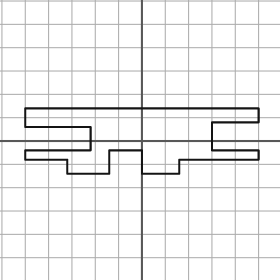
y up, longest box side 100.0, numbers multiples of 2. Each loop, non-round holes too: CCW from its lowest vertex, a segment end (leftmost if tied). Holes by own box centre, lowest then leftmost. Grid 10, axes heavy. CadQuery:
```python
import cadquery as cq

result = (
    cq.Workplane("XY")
    .moveTo(-32.0, -14.0)
    .lineTo(-14.0, -14.0)
    .lineTo(-14.0, -4.0)
    .lineTo(0.0, -4.0)
    .lineTo(0.0, -14.0)
    .lineTo(16.0, -14.0)
    .lineTo(16.0, -8.0)
    .lineTo(50.0, -8.0)
    .lineTo(50.0, -4.0)
    .lineTo(30.0, -4.0)
    .lineTo(30.0, 8.0)
    .lineTo(50.0, 8.0)
    .lineTo(50.0, 14.0)
    .lineTo(-50.0, 14.0)
    .lineTo(-50.0, 6.0)
    .lineTo(-22.0, 6.0)
    .lineTo(-22.0, -4.0)
    .lineTo(-50.0, -4.0)
    .lineTo(-50.0, -8.0)
    .lineTo(-32.0, -8.0)
    .close()
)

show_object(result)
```